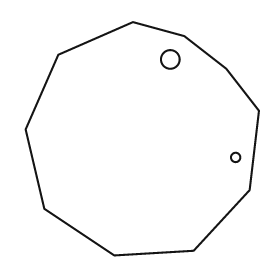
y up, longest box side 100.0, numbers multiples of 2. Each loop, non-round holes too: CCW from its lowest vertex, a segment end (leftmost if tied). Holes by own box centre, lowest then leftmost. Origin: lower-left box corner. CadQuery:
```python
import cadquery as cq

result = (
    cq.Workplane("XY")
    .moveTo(38.0, 0.0)
    .lineTo(72.0, 2.0)
    .lineTo(96.0, 28.0)
    .lineTo(100.0, 62.0)
    .lineTo(86.0, 80.0)
    .lineTo(68.0, 94.0)
    .lineTo(46.0, 100.0)
    .lineTo(14.0, 86.0)
    .lineTo(0.0, 54.0)
    .lineTo(8.0, 20.0)
    .close()
    .moveTo(90.0, 42.0)
    .circle(2.0)
    .moveTo(62.0, 84.0)
    .circle(4.0)
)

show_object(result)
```